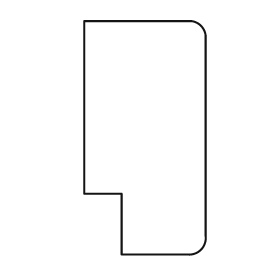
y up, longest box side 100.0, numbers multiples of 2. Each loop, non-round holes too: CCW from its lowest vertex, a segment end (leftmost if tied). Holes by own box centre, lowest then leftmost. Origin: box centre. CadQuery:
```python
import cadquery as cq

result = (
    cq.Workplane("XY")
    .moveTo(-10.0, -50.0)
    .lineTo(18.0, -50.0)
    .threePointArc((24.0, -48.0), (26.0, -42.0))
    .lineTo(26.0, 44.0)
    .threePointArc((24.0, 48.0), (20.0, 50.0))
    .lineTo(-26.0, 50.0)
    .lineTo(-26.0, -24.0)
    .lineTo(-10.0, -24.0)
    .close()
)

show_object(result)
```